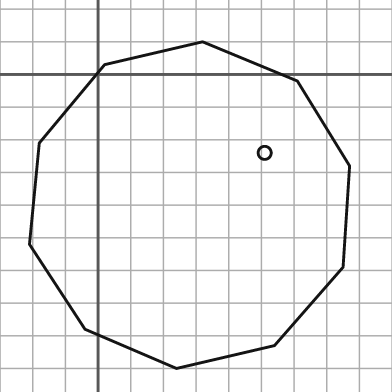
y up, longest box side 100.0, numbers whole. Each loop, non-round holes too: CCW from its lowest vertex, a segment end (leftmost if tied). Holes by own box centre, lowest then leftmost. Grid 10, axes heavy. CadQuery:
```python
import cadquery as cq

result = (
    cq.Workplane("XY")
    .moveTo(24.0, -90.0)
    .lineTo(54.0, -83.0)
    .lineTo(75.0, -59.0)
    .lineTo(77.0, -28.0)
    .lineTo(61.0, -2.0)
    .lineTo(32.0, 10.0)
    .lineTo(2.0, 3.0)
    .lineTo(-18.0, -21.0)
    .lineTo(-21.0, -52.0)
    .lineTo(-4.0, -78.0)
    .close()
    .moveTo(51.0, -24.0)
    .circle(2.0)
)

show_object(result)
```